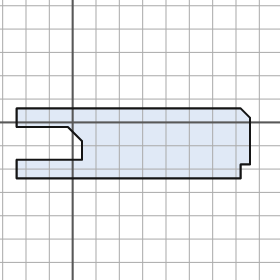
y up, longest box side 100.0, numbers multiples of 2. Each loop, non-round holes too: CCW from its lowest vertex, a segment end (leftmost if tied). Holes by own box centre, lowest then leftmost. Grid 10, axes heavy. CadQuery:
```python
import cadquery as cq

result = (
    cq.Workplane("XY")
    .moveTo(-24.0, -24.0)
    .lineTo(72.0, -24.0)
    .lineTo(72.0, -18.0)
    .lineTo(76.0, -18.0)
    .lineTo(76.0, 2.0)
    .lineTo(72.0, 6.0)
    .lineTo(-24.0, 6.0)
    .lineTo(-24.0, -2.0)
    .lineTo(-2.0, -2.0)
    .lineTo(4.0, -8.0)
    .lineTo(4.0, -16.0)
    .lineTo(-24.0, -16.0)
    .close()
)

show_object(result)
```